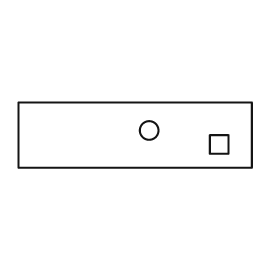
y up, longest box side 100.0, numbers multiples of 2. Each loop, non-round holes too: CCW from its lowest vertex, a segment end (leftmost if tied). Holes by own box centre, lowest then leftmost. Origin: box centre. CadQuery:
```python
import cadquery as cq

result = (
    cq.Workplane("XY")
    .moveTo(-50.0, -14.0)
    .lineTo(50.0, -14.0)
    .lineTo(50.0, 14.0)
    .lineTo(-50.0, 14.0)
    .close()
    .moveTo(32.0, -8.0)
    .lineTo(40.0, -8.0)
    .lineTo(40.0, 0.0)
    .lineTo(32.0, 0.0)
    .close()
    .moveTo(6.0, 2.0)
    .circle(4.0)
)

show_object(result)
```